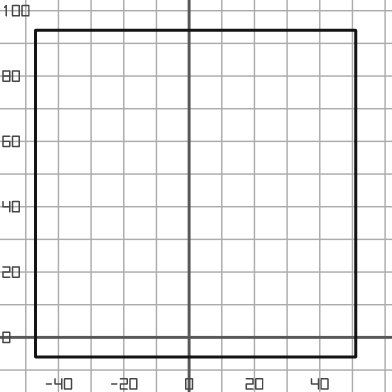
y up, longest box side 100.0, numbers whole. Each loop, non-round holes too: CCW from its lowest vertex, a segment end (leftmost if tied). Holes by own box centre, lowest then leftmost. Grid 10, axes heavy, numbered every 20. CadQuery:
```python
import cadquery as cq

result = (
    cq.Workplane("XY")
    .moveTo(-47.0, -6.0)
    .lineTo(51.0, -6.0)
    .lineTo(51.0, 94.0)
    .lineTo(-47.0, 94.0)
    .close()
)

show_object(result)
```